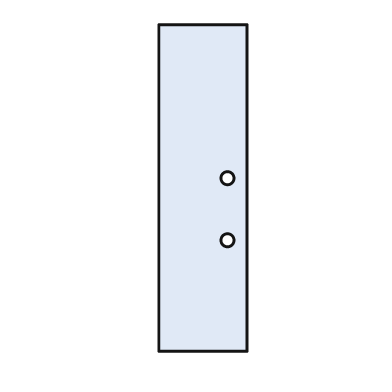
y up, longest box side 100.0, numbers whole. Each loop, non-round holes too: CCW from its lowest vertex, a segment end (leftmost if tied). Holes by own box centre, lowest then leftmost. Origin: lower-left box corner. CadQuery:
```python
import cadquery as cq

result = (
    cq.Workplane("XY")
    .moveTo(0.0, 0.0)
    .lineTo(27.0, 0.0)
    .lineTo(27.0, 100.0)
    .lineTo(0.0, 100.0)
    .close()
    .moveTo(21.0, 34.0)
    .circle(2.0)
    .moveTo(21.0, 53.0)
    .circle(2.0)
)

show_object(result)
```